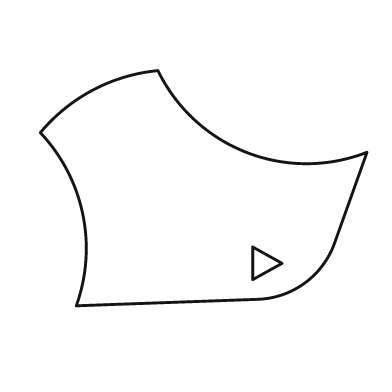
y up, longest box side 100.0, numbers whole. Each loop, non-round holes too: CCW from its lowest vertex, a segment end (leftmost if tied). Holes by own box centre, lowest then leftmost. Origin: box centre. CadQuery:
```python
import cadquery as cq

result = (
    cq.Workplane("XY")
    .moveTo(-39.0, -36.0)
    .lineTo(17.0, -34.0)
    .threePointArc((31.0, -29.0), (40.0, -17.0))
    .lineTo(50.0, 11.0)
    .threePointArc((13.0, 11.0), (-14.0, 36.0))
    .threePointArc((-34.0, 30.0), (-50.0, 17.0))
    .threePointArc((-37.0, -8.0), (-39.0, -36.0))
    .close()
    .moveTo(15.0, -28.0)
    .lineTo(24.0, -23.0)
    .lineTo(15.0, -18.0)
    .close()
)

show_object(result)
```